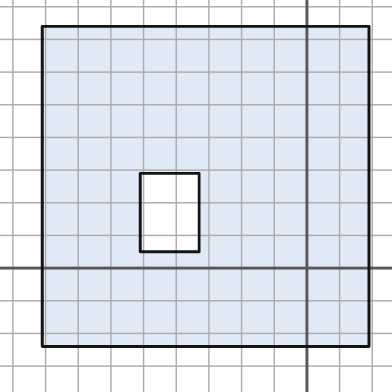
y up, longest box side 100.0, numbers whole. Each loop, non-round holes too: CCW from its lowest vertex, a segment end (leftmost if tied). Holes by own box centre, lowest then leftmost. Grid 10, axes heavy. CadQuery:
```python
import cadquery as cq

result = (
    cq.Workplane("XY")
    .moveTo(-81.0, -24.0)
    .lineTo(19.0, -24.0)
    .lineTo(19.0, 74.0)
    .lineTo(-81.0, 74.0)
    .close()
    .moveTo(-51.0, 5.0)
    .lineTo(-33.0, 5.0)
    .lineTo(-33.0, 29.0)
    .lineTo(-51.0, 29.0)
    .close()
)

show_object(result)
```